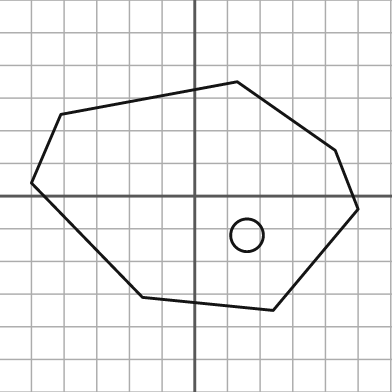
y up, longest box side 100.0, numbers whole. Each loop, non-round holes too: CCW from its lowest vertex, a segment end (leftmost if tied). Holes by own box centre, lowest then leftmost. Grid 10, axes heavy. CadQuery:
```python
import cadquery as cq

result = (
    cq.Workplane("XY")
    .moveTo(24.0, -35.0)
    .lineTo(50.0, -4.0)
    .lineTo(43.0, 14.0)
    .lineTo(13.0, 35.0)
    .lineTo(-41.0, 25.0)
    .lineTo(-50.0, 4.0)
    .lineTo(-16.0, -31.0)
    .close()
    .moveTo(16.0, -12.0)
    .circle(5.0)
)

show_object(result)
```